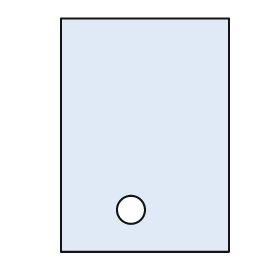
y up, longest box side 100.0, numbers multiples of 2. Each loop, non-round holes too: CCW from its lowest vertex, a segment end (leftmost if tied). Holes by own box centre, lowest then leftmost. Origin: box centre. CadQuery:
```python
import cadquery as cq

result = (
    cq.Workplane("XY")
    .moveTo(-36.0, -50.0)
    .lineTo(36.0, -50.0)
    .lineTo(36.0, 50.0)
    .lineTo(-36.0, 50.0)
    .close()
    .moveTo(-6.0, -32.0)
    .circle(6.0)
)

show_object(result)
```